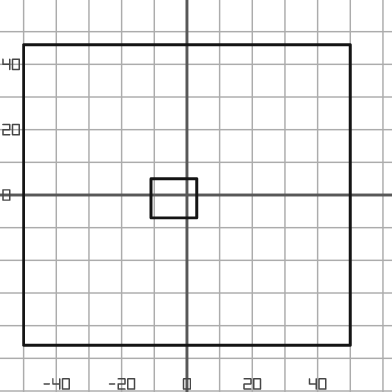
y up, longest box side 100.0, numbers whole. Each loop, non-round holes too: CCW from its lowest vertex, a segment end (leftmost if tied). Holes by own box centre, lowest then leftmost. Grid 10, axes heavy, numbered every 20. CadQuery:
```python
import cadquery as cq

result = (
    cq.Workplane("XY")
    .moveTo(-50.0, -46.0)
    .lineTo(50.0, -46.0)
    .lineTo(50.0, 46.0)
    .lineTo(-50.0, 46.0)
    .close()
    .moveTo(-11.0, -7.0)
    .lineTo(3.0, -7.0)
    .lineTo(3.0, 5.0)
    .lineTo(-11.0, 5.0)
    .close()
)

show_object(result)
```